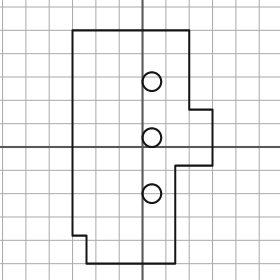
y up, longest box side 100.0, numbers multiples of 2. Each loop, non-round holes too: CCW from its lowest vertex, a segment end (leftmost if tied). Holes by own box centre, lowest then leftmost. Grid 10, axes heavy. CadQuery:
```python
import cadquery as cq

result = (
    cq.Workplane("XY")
    .moveTo(-24.0, -50.0)
    .lineTo(14.0, -50.0)
    .lineTo(14.0, -8.0)
    .lineTo(30.0, -8.0)
    .lineTo(30.0, 16.0)
    .lineTo(20.0, 16.0)
    .lineTo(20.0, 50.0)
    .lineTo(-30.0, 50.0)
    .lineTo(-30.0, -38.0)
    .lineTo(-24.0, -38.0)
    .close()
    .moveTo(4.0, -20.0)
    .circle(4.0)
    .moveTo(4.0, 4.0)
    .circle(4.0)
    .moveTo(4.0, 28.0)
    .circle(4.0)
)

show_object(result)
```